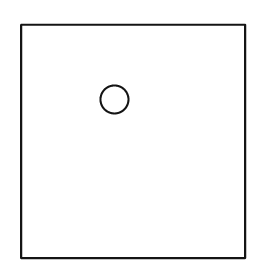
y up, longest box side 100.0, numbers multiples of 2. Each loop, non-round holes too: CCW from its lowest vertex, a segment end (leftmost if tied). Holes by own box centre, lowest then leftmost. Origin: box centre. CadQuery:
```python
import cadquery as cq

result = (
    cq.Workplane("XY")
    .moveTo(-48.0, -50.0)
    .lineTo(48.0, -50.0)
    .lineTo(48.0, 50.0)
    .lineTo(-48.0, 50.0)
    .close()
    .moveTo(-8.0, 18.0)
    .circle(6.0)
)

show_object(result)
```